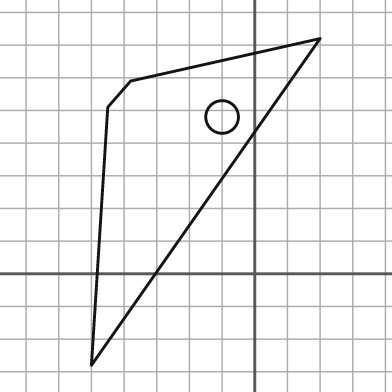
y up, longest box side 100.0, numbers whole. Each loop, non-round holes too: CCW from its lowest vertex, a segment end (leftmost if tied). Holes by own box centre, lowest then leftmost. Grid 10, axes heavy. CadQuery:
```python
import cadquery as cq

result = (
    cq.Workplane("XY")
    .moveTo(-50.0, -28.0)
    .lineTo(20.0, 72.0)
    .lineTo(-38.0, 59.0)
    .lineTo(-45.0, 51.0)
    .close()
    .moveTo(-10.0, 48.0)
    .circle(5.0)
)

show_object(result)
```